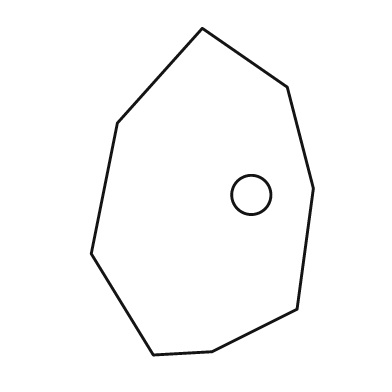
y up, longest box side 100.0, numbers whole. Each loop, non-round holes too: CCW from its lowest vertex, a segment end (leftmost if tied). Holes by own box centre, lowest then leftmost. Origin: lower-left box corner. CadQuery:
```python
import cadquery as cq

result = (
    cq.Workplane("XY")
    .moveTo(19.0, 0.0)
    .lineTo(37.0, 1.0)
    .lineTo(63.0, 14.0)
    .lineTo(68.0, 51.0)
    .lineTo(60.0, 82.0)
    .lineTo(34.0, 100.0)
    .lineTo(8.0, 71.0)
    .lineTo(0.0, 31.0)
    .close()
    .moveTo(49.0, 49.0)
    .circle(6.0)
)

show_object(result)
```